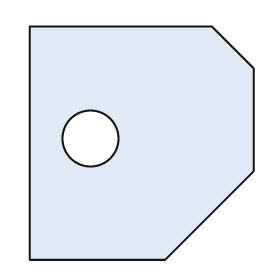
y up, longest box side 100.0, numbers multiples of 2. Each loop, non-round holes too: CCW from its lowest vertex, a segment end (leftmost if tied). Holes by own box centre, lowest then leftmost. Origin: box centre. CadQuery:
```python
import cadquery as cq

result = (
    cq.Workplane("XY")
    .moveTo(-48.0, -50.0)
    .lineTo(10.0, -50.0)
    .lineTo(48.0, -12.0)
    .lineTo(48.0, 32.0)
    .lineTo(30.0, 50.0)
    .lineTo(-48.0, 50.0)
    .close()
    .moveTo(-22.0, 2.0)
    .circle(12.0)
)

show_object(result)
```